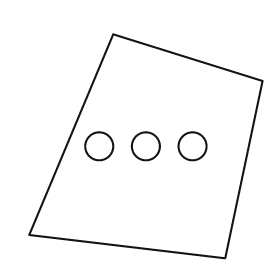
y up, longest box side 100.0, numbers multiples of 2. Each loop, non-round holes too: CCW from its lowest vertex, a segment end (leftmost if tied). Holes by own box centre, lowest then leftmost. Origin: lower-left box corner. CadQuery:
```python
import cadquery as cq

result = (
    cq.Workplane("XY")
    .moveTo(84.0, 0.0)
    .lineTo(100.0, 76.0)
    .lineTo(36.0, 96.0)
    .lineTo(0.0, 10.0)
    .close()
    .moveTo(30.0, 48.0)
    .circle(6.0)
    .moveTo(50.0, 48.0)
    .circle(6.0)
    .moveTo(70.0, 48.0)
    .circle(6.0)
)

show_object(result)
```